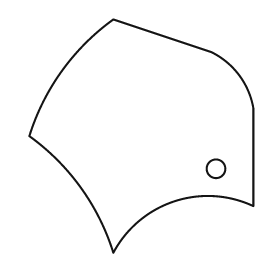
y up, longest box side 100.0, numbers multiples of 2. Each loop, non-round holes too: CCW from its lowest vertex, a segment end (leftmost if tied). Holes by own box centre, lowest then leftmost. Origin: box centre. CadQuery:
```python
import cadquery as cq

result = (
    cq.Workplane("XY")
    .moveTo(-12.0, -50.0)
    .threePointArc((14.0, -28.0), (48.0, -30.0))
    .lineTo(48.0, 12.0)
    .threePointArc((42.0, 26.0), (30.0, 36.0))
    .lineTo(-12.0, 50.0)
    .threePointArc((-34.0, 28.0), (-48.0, 0.0))
    .threePointArc((-26.0, -22.0), (-12.0, -50.0))
    .close()
    .moveTo(32.0, -14.0)
    .circle(4.0)
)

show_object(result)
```